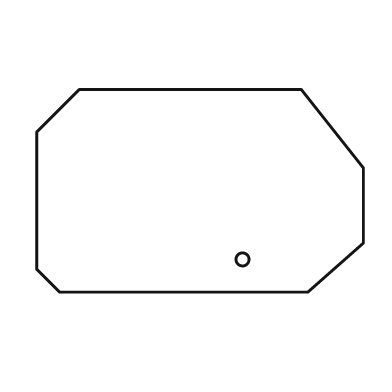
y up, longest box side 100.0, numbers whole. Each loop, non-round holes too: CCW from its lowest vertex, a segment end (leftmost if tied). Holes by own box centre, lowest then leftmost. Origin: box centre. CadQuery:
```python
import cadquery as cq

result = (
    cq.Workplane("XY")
    .moveTo(-43.0, -31.0)
    .lineTo(33.0, -31.0)
    .lineTo(50.0, -16.0)
    .lineTo(50.0, 7.0)
    .lineTo(31.0, 31.0)
    .lineTo(-37.0, 31.0)
    .lineTo(-50.0, 18.0)
    .lineTo(-50.0, -24.0)
    .close()
    .moveTo(13.0, -21.0)
    .circle(2.0)
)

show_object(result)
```